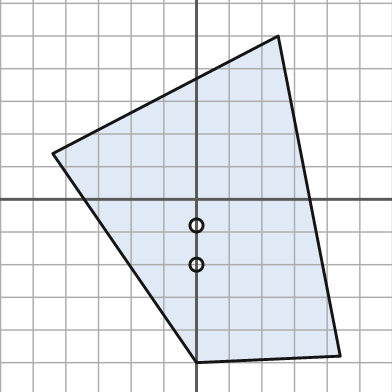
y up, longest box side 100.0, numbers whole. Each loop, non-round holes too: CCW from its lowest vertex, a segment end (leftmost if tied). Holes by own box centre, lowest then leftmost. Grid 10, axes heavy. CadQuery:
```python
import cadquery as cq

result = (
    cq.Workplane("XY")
    .moveTo(0.0, -50.0)
    .lineTo(44.0, -48.0)
    .lineTo(25.0, 50.0)
    .lineTo(-44.0, 14.0)
    .close()
    .moveTo(0.0, -20.0)
    .circle(2.0)
    .moveTo(0.0, -8.0)
    .circle(2.0)
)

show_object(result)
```